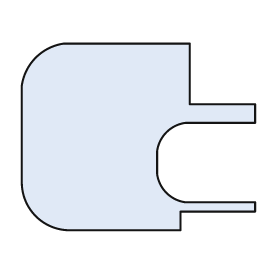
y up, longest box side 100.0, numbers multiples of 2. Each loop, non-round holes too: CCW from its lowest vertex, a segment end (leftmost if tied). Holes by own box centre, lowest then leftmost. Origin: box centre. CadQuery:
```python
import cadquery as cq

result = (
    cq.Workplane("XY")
    .moveTo(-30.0, -40.0)
    .lineTo(18.0, -40.0)
    .lineTo(18.0, -32.0)
    .lineTo(50.0, -32.0)
    .lineTo(50.0, -28.0)
    .lineTo(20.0, -28.0)
    .threePointArc((12.0, -24.0), (8.0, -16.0))
    .lineTo(8.0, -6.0)
    .threePointArc((12.0, 2.0), (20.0, 6.0))
    .lineTo(50.0, 6.0)
    .lineTo(50.0, 14.0)
    .lineTo(22.0, 14.0)
    .lineTo(22.0, 40.0)
    .lineTo(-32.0, 40.0)
    .threePointArc((-44.0, 34.0), (-50.0, 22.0))
    .lineTo(-50.0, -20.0)
    .threePointArc((-44.0, -34.0), (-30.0, -40.0))
    .close()
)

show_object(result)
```